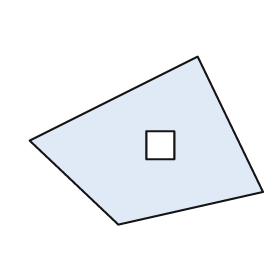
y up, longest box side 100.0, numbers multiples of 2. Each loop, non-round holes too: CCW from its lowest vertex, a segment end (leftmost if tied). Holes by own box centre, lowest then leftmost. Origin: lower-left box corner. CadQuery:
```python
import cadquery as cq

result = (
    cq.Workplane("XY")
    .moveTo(38.0, 0.0)
    .lineTo(100.0, 14.0)
    .lineTo(72.0, 72.0)
    .lineTo(0.0, 36.0)
    .close()
    .moveTo(50.0, 28.0)
    .lineTo(62.0, 28.0)
    .lineTo(62.0, 40.0)
    .lineTo(50.0, 40.0)
    .close()
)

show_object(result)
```